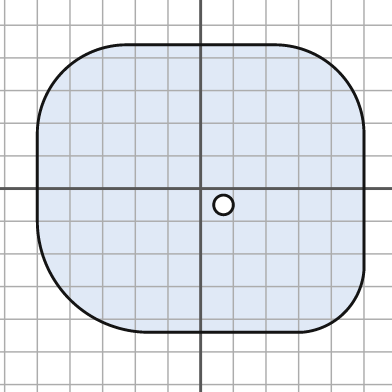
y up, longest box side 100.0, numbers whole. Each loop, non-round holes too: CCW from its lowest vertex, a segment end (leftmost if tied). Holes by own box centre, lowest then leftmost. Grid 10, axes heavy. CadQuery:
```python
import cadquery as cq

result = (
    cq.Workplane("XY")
    .moveTo(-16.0, -44.0)
    .lineTo(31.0, -44.0)
    .threePointArc((44.0, -38.0), (50.0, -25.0))
    .lineTo(50.0, 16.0)
    .threePointArc((42.0, 36.0), (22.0, 44.0))
    .lineTo(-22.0, 44.0)
    .threePointArc((-42.0, 36.0), (-50.0, 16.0))
    .lineTo(-50.0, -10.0)
    .threePointArc((-40.0, -34.0), (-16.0, -44.0))
    .close()
    .moveTo(7.0, -5.0)
    .circle(3.0)
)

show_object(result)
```